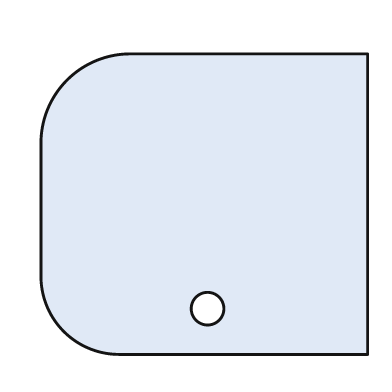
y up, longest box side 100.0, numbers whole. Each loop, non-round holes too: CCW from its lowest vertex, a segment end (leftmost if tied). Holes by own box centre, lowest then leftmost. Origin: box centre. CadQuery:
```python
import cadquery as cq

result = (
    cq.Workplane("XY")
    .moveTo(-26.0, -46.0)
    .lineTo(50.0, -46.0)
    .lineTo(50.0, 46.0)
    .lineTo(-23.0, 46.0)
    .threePointArc((-42.0, 38.0), (-50.0, 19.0))
    .lineTo(-50.0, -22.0)
    .threePointArc((-43.0, -39.0), (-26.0, -46.0))
    .close()
    .moveTo(1.0, -32.0)
    .circle(5.0)
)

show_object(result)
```